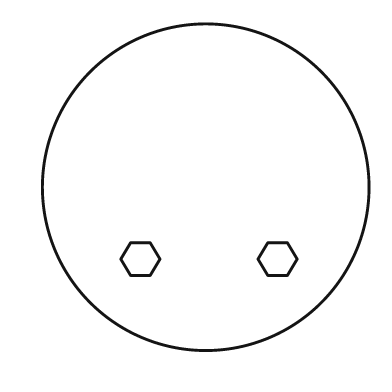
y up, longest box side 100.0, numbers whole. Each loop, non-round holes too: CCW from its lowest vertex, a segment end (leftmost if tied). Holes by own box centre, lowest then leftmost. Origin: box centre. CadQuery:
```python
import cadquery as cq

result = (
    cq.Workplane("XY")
    .moveTo(0.0, 0.0)
    .circle(50.0)
    .moveTo(-23.0, -27.0)
    .lineTo(-17.0, -27.0)
    .lineTo(-14.0, -22.0)
    .lineTo(-17.0, -17.0)
    .lineTo(-23.0, -17.0)
    .lineTo(-26.0, -22.0)
    .close()
    .moveTo(19.0, -27.0)
    .lineTo(25.0, -27.0)
    .lineTo(28.0, -22.0)
    .lineTo(25.0, -17.0)
    .lineTo(19.0, -17.0)
    .lineTo(16.0, -22.0)
    .close()
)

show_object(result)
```